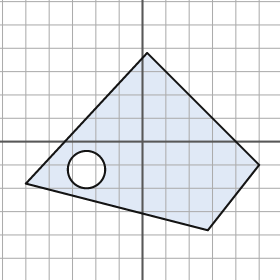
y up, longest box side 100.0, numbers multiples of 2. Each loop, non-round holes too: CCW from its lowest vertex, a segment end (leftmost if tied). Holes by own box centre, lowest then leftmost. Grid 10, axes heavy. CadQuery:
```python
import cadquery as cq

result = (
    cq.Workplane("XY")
    .moveTo(28.0, -38.0)
    .lineTo(50.0, -10.0)
    .lineTo(2.0, 38.0)
    .lineTo(-50.0, -18.0)
    .close()
    .moveTo(-24.0, -12.0)
    .circle(8.0)
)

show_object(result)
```